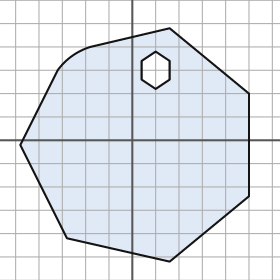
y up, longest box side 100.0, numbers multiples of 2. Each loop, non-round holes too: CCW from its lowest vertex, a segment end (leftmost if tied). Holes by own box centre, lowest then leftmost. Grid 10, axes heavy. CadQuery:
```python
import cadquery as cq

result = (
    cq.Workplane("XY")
    .moveTo(16.0, -52.0)
    .lineTo(50.0, -24.0)
    .lineTo(50.0, 20.0)
    .lineTo(16.0, 48.0)
    .lineTo(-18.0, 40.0)
    .threePointArc((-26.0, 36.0), (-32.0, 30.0))
    .lineTo(-48.0, -2.0)
    .lineTo(-28.0, -42.0)
    .close()
    .moveTo(10.0, 22.0)
    .lineTo(16.0, 26.0)
    .lineTo(16.0, 34.0)
    .lineTo(10.0, 38.0)
    .lineTo(4.0, 34.0)
    .lineTo(4.0, 26.0)
    .close()
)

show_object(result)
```